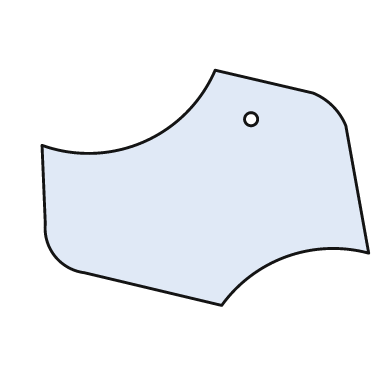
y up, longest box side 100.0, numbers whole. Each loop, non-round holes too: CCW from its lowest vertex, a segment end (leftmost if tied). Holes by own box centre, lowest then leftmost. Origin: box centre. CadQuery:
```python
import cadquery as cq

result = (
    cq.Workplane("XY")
    .moveTo(5.0, -36.0)
    .threePointArc((25.0, -21.0), (50.0, -20.0))
    .lineTo(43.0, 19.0)
    .threePointArc((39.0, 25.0), (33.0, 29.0))
    .lineTo(3.0, 36.0)
    .threePointArc((-19.0, 14.0), (-50.0, 13.0))
    .lineTo(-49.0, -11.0)
    .threePointArc((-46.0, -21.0), (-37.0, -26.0))
    .close()
    .moveTo(14.0, 21.0)
    .circle(2.0)
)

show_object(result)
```